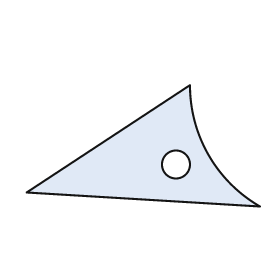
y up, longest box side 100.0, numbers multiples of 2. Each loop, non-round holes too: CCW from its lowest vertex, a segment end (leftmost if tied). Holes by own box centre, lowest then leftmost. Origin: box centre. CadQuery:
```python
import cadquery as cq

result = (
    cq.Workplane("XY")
    .moveTo(50.0, -26.0)
    .threePointArc((28.0, -4.0), (20.0, 26.0))
    .lineTo(-50.0, -20.0)
    .close()
    .moveTo(14.0, -8.0)
    .circle(6.0)
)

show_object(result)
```